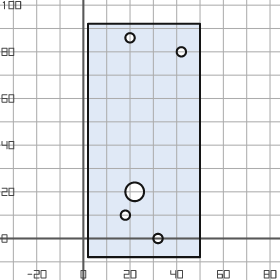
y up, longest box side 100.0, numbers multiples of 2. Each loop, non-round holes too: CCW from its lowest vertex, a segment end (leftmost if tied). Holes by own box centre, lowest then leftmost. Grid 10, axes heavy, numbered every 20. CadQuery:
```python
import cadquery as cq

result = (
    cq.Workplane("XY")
    .moveTo(2.0, -8.0)
    .lineTo(50.0, -8.0)
    .lineTo(50.0, 92.0)
    .lineTo(2.0, 92.0)
    .close()
    .moveTo(32.0, 0.0)
    .circle(2.0)
    .moveTo(18.0, 10.0)
    .circle(2.0)
    .moveTo(22.0, 20.0)
    .circle(4.0)
    .moveTo(42.0, 80.0)
    .circle(2.0)
    .moveTo(20.0, 86.0)
    .circle(2.0)
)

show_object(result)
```